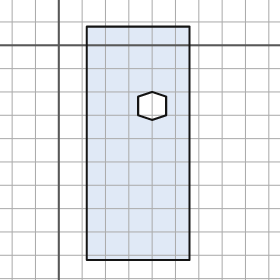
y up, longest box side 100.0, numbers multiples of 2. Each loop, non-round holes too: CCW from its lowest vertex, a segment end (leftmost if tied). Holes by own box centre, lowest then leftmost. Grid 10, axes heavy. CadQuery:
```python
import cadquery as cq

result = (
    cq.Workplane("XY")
    .moveTo(12.0, -92.0)
    .lineTo(56.0, -92.0)
    .lineTo(56.0, 8.0)
    .lineTo(12.0, 8.0)
    .close()
    .moveTo(40.0, -32.0)
    .lineTo(46.0, -30.0)
    .lineTo(46.0, -22.0)
    .lineTo(40.0, -20.0)
    .lineTo(34.0, -22.0)
    .lineTo(34.0, -30.0)
    .close()
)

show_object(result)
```